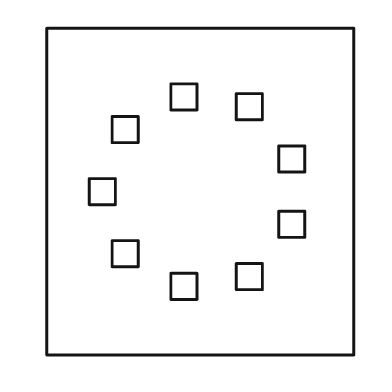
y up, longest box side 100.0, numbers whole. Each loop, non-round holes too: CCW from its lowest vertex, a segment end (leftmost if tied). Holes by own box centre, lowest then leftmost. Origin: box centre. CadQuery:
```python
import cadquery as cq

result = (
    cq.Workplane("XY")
    .moveTo(-47.0, -50.0)
    .lineTo(47.0, -50.0)
    .lineTo(47.0, 50.0)
    .lineTo(-47.0, 50.0)
    .close()
    .moveTo(-9.0, -33.0)
    .lineTo(-1.0, -33.0)
    .lineTo(-1.0, -25.0)
    .lineTo(-9.0, -25.0)
    .close()
    .moveTo(11.0, -30.0)
    .lineTo(19.0, -30.0)
    .lineTo(19.0, -22.0)
    .lineTo(11.0, -22.0)
    .close()
    .moveTo(-27.0, -23.0)
    .lineTo(-19.0, -23.0)
    .lineTo(-19.0, -15.0)
    .lineTo(-27.0, -15.0)
    .close()
    .moveTo(24.0, -14.0)
    .lineTo(32.0, -14.0)
    .lineTo(32.0, -6.0)
    .lineTo(24.0, -6.0)
    .close()
    .moveTo(-34.0, -4.0)
    .lineTo(-26.0, -4.0)
    .lineTo(-26.0, 4.0)
    .lineTo(-34.0, 4.0)
    .close()
    .moveTo(24.0, 6.0)
    .lineTo(32.0, 6.0)
    .lineTo(32.0, 14.0)
    .lineTo(24.0, 14.0)
    .close()
    .moveTo(-27.0, 15.0)
    .lineTo(-19.0, 15.0)
    .lineTo(-19.0, 23.0)
    .lineTo(-27.0, 23.0)
    .close()
    .moveTo(11.0, 22.0)
    .lineTo(19.0, 22.0)
    .lineTo(19.0, 30.0)
    .lineTo(11.0, 30.0)
    .close()
    .moveTo(-9.0, 25.0)
    .lineTo(-1.0, 25.0)
    .lineTo(-1.0, 33.0)
    .lineTo(-9.0, 33.0)
    .close()
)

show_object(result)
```